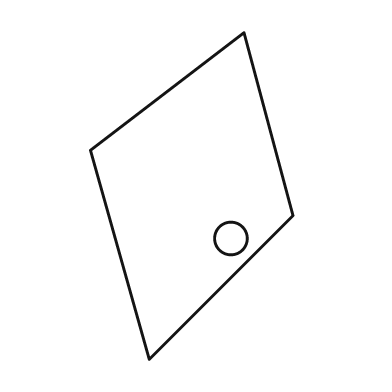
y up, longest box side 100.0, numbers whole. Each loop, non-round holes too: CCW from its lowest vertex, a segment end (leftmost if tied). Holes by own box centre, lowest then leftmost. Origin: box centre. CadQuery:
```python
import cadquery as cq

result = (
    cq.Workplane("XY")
    .moveTo(-13.0, -50.0)
    .lineTo(31.0, -6.0)
    .lineTo(16.0, 50.0)
    .lineTo(-31.0, 14.0)
    .close()
    .moveTo(12.0, -13.0)
    .circle(5.0)
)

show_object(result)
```